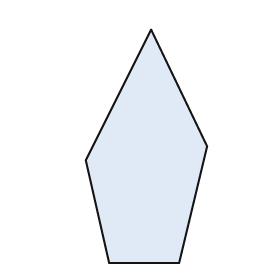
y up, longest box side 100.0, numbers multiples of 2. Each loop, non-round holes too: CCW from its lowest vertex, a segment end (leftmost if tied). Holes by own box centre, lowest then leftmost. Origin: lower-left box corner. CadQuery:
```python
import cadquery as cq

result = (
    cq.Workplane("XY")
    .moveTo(10.0, 0.0)
    .lineTo(40.0, 0.0)
    .lineTo(52.0, 50.0)
    .lineTo(28.0, 100.0)
    .lineTo(0.0, 44.0)
    .close()
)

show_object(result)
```